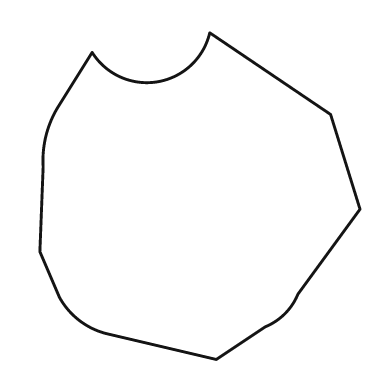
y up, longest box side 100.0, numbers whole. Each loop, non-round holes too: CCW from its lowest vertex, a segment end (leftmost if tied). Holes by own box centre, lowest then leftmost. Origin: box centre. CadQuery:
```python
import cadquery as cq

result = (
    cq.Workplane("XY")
    .moveTo(5.0, -50.0)
    .lineTo(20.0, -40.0)
    .threePointArc((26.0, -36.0), (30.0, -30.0))
    .lineTo(49.0, -4.0)
    .lineTo(40.0, 25.0)
    .lineTo(3.0, 50.0)
    .threePointArc((-13.0, 35.0), (-33.0, 44.0))
    .lineTo(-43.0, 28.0)
    .threePointArc((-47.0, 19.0), (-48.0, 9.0))
    .lineTo(-49.0, -17.0)
    .lineTo(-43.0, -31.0)
    .threePointArc((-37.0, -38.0), (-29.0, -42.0))
    .close()
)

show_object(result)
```